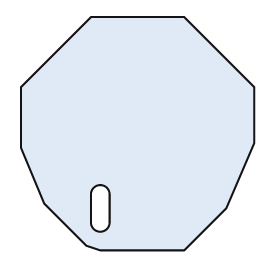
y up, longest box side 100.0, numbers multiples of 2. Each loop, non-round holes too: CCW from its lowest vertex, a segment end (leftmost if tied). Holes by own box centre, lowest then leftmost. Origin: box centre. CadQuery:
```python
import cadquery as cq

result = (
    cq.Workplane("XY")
    .moveTo(-16.0, -50.0)
    .lineTo(20.0, -50.0)
    .lineTo(38.0, -32.0)
    .lineTo(50.0, -4.0)
    .lineTo(50.0, 20.0)
    .lineTo(20.0, 50.0)
    .lineTo(-20.0, 50.0)
    .lineTo(-50.0, 20.0)
    .lineTo(-50.0, -6.0)
    .lineTo(-40.0, -30.0)
    .lineTo(-22.0, -48.0)
    .close()
    .moveTo(-20.0, -38.0)
    .threePointArc((-16.0, -42.0), (-12.0, -38.0))
    .lineTo(-12.0, -26.0)
    .threePointArc((-16.0, -22.0), (-20.0, -26.0))
    .close()
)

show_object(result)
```